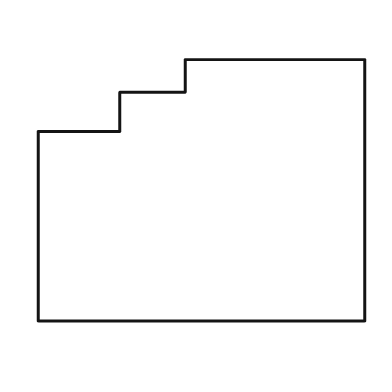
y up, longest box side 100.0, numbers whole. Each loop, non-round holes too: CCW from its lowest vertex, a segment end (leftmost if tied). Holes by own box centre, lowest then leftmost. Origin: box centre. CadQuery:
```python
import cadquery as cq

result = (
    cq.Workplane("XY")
    .moveTo(-50.0, -40.0)
    .lineTo(50.0, -40.0)
    .lineTo(50.0, 40.0)
    .lineTo(-5.0, 40.0)
    .lineTo(-5.0, 30.0)
    .lineTo(-25.0, 30.0)
    .lineTo(-25.0, 18.0)
    .lineTo(-50.0, 18.0)
    .close()
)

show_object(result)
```